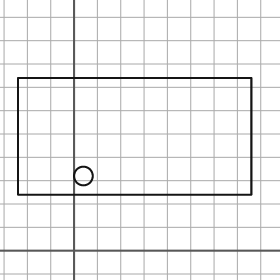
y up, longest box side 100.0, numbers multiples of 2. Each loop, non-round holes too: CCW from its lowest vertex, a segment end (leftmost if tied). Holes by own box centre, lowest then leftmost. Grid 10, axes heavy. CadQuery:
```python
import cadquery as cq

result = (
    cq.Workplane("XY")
    .moveTo(-24.0, 24.0)
    .lineTo(76.0, 24.0)
    .lineTo(76.0, 74.0)
    .lineTo(-24.0, 74.0)
    .close()
    .moveTo(4.0, 32.0)
    .circle(4.0)
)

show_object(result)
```